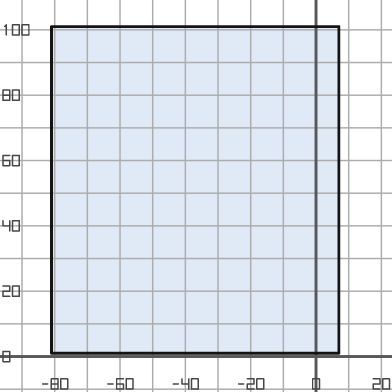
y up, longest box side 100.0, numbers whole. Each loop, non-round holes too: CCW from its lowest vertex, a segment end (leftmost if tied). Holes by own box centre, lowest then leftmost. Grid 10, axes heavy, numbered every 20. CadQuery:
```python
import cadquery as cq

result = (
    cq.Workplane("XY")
    .moveTo(-81.0, 1.0)
    .lineTo(7.0, 1.0)
    .lineTo(7.0, 101.0)
    .lineTo(-81.0, 101.0)
    .close()
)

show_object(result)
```